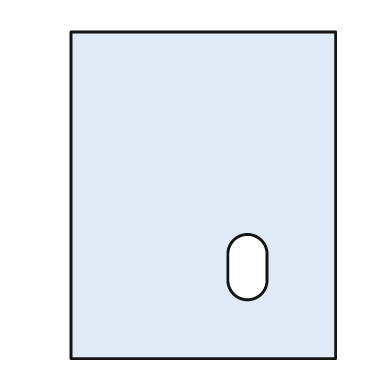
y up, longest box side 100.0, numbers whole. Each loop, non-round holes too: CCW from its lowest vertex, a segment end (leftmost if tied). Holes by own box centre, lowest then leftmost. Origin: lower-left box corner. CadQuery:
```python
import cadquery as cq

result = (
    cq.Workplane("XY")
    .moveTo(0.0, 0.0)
    .lineTo(81.0, 0.0)
    .lineTo(81.0, 100.0)
    .lineTo(0.0, 100.0)
    .close()
    .moveTo(48.0, 24.0)
    .threePointArc((54.0, 18.0), (60.0, 24.0))
    .lineTo(60.0, 32.0)
    .threePointArc((54.0, 38.0), (48.0, 32.0))
    .close()
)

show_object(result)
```